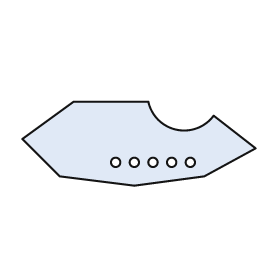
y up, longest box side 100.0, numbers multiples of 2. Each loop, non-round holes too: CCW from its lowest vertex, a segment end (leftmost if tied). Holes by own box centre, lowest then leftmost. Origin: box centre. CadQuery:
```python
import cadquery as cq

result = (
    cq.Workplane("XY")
    .moveTo(-2.0, -18.0)
    .lineTo(28.0, -14.0)
    .lineTo(50.0, -2.0)
    .lineTo(32.0, 12.0)
    .threePointArc((16.0, 6.0), (4.0, 18.0))
    .lineTo(-28.0, 18.0)
    .lineTo(-50.0, 2.0)
    .lineTo(-34.0, -14.0)
    .close()
    .moveTo(-10.0, -8.0)
    .circle(2.0)
    .moveTo(-2.0, -8.0)
    .circle(2.0)
    .moveTo(6.0, -8.0)
    .circle(2.0)
    .moveTo(14.0, -8.0)
    .circle(2.0)
    .moveTo(22.0, -8.0)
    .circle(2.0)
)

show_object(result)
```